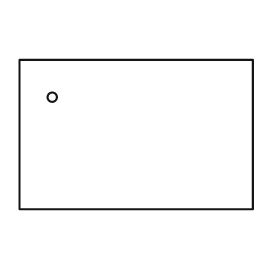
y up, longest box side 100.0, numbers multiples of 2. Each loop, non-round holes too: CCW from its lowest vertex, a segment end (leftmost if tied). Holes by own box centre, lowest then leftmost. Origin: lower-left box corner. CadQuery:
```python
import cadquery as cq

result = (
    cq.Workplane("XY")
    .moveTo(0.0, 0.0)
    .lineTo(100.0, 0.0)
    .lineTo(100.0, 64.0)
    .lineTo(0.0, 64.0)
    .close()
    .moveTo(14.0, 48.0)
    .circle(2.0)
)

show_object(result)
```